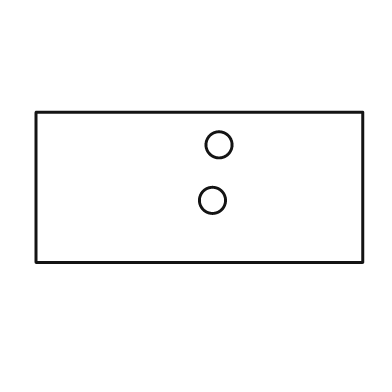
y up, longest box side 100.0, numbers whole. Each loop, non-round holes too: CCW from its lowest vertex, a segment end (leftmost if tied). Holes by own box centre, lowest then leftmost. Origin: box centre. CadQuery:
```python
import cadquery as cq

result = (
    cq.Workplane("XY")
    .moveTo(-50.0, -23.0)
    .lineTo(50.0, -23.0)
    .lineTo(50.0, 23.0)
    .lineTo(-50.0, 23.0)
    .close()
    .moveTo(4.0, -4.0)
    .circle(4.0)
    .moveTo(6.0, 13.0)
    .circle(4.0)
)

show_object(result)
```